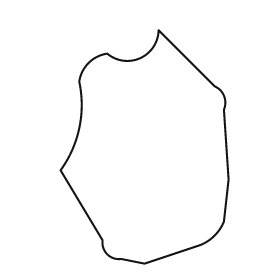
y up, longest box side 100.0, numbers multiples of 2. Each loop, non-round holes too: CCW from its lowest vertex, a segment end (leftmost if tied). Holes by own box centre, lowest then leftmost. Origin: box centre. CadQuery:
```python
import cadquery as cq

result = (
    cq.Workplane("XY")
    .moveTo(0.0, -50.0)
    .lineTo(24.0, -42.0)
    .threePointArc((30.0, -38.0), (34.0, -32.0))
    .lineTo(36.0, -14.0)
    .lineTo(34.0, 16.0)
    .threePointArc((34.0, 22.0), (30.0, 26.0))
    .lineTo(6.0, 50.0)
    .threePointArc((-2.0, 38.0), (-16.0, 40.0))
    .threePointArc((-24.0, 36.0), (-28.0, 28.0))
    .threePointArc((-28.0, 8.0), (-36.0, -10.0))
    .lineTo(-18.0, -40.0)
    .threePointArc((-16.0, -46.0), (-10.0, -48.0))
    .close()
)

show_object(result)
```